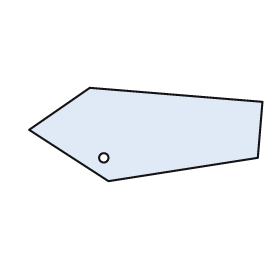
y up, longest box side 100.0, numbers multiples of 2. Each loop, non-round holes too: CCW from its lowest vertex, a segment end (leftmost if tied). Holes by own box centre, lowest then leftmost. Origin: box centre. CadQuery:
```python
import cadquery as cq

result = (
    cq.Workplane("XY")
    .moveTo(-16.0, -20.0)
    .lineTo(48.0, -10.0)
    .lineTo(50.0, 14.0)
    .lineTo(-24.0, 20.0)
    .lineTo(-50.0, 2.0)
    .close()
    .moveTo(-18.0, -10.0)
    .circle(2.0)
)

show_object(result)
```